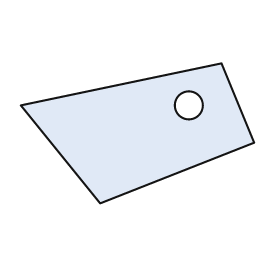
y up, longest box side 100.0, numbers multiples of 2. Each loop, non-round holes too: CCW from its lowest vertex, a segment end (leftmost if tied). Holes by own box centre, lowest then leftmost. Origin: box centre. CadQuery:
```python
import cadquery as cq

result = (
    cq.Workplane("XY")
    .moveTo(-16.0, -30.0)
    .lineTo(50.0, -4.0)
    .lineTo(36.0, 30.0)
    .lineTo(-50.0, 12.0)
    .close()
    .moveTo(22.0, 12.0)
    .circle(6.0)
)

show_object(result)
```